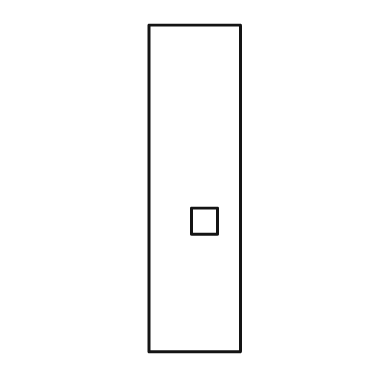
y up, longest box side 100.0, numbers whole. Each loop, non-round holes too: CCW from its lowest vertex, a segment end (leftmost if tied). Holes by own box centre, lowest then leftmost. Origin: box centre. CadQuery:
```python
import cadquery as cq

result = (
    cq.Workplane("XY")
    .moveTo(-14.0, -50.0)
    .lineTo(14.0, -50.0)
    .lineTo(14.0, 50.0)
    .lineTo(-14.0, 50.0)
    .close()
    .moveTo(-1.0, -14.0)
    .lineTo(7.0, -14.0)
    .lineTo(7.0, -6.0)
    .lineTo(-1.0, -6.0)
    .close()
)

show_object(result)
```